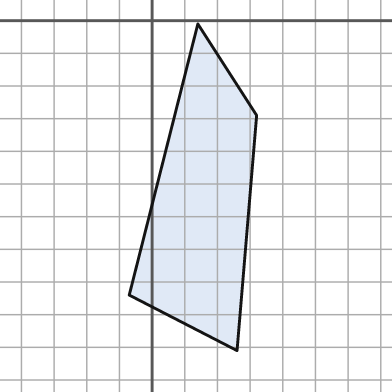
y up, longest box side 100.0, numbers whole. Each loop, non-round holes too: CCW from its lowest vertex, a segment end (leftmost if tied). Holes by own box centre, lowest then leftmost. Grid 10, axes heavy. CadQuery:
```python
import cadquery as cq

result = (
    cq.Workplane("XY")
    .moveTo(26.0, -101.0)
    .lineTo(32.0, -29.0)
    .lineTo(14.0, -1.0)
    .lineTo(-7.0, -84.0)
    .close()
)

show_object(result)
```